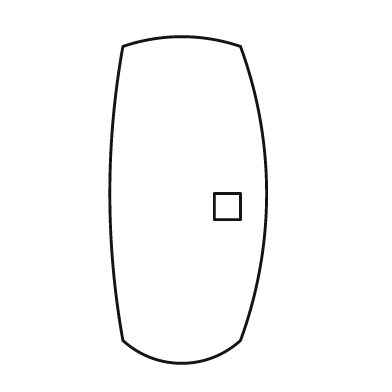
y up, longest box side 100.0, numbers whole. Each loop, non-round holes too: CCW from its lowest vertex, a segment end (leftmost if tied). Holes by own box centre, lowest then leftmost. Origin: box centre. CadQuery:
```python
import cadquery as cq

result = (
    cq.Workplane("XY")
    .moveTo(-20.0, -43.0)
    .threePointArc((-2.0, -50.0), (16.0, -43.0))
    .threePointArc((24.0, 2.0), (16.0, 47.0))
    .threePointArc((-2.0, 50.0), (-20.0, 47.0))
    .threePointArc((-24.0, 2.0), (-20.0, -43.0))
    .close()
    .moveTo(8.0, -6.0)
    .lineTo(16.0, -6.0)
    .lineTo(16.0, 2.0)
    .lineTo(8.0, 2.0)
    .close()
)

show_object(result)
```